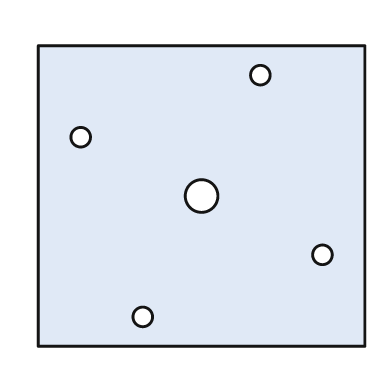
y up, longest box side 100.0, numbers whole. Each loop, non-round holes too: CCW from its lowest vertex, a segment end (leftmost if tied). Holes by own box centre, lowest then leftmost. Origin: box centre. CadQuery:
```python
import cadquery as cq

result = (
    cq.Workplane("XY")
    .moveTo(-50.0, -46.0)
    .lineTo(50.0, -46.0)
    .lineTo(50.0, 46.0)
    .lineTo(-50.0, 46.0)
    .close()
    .moveTo(-18.0, -37.0)
    .circle(3.0)
    .moveTo(37.0, -18.0)
    .circle(3.0)
    .moveTo(0.0, 0.0)
    .circle(5.0)
    .moveTo(-37.0, 18.0)
    .circle(3.0)
    .moveTo(18.0, 37.0)
    .circle(3.0)
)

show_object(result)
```